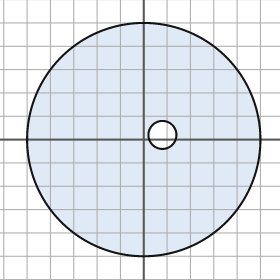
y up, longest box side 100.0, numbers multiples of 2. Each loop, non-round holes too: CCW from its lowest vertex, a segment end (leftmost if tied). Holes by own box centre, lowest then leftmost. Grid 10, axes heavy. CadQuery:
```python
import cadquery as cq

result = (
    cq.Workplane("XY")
    .moveTo(0.0, 0.0)
    .circle(50.0)
    .moveTo(8.0, 2.0)
    .circle(6.0)
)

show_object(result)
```